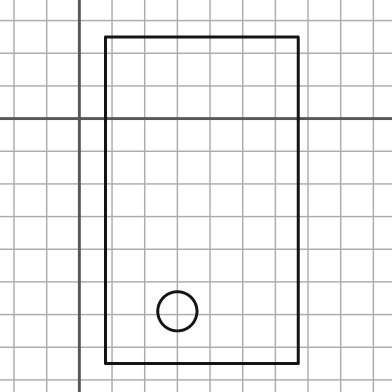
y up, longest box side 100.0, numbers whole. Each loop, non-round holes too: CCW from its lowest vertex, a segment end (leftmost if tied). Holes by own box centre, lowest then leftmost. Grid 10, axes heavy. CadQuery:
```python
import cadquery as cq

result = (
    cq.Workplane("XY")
    .moveTo(8.0, -75.0)
    .lineTo(67.0, -75.0)
    .lineTo(67.0, 25.0)
    .lineTo(8.0, 25.0)
    .close()
    .moveTo(30.0, -59.0)
    .circle(6.0)
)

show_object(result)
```